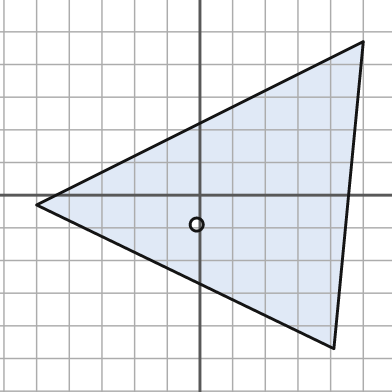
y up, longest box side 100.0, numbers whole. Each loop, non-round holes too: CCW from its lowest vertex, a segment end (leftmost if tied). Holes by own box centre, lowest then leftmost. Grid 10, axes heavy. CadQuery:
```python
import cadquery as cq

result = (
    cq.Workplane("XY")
    .moveTo(41.0, -47.0)
    .lineTo(50.0, 47.0)
    .lineTo(-50.0, -3.0)
    .close()
    .moveTo(-1.0, -9.0)
    .circle(2.0)
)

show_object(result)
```